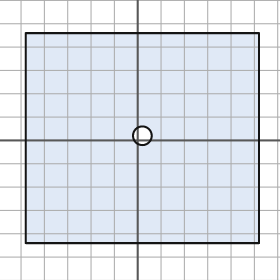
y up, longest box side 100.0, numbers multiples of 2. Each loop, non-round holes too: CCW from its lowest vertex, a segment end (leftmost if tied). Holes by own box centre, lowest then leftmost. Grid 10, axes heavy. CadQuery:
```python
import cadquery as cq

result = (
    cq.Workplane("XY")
    .moveTo(-48.0, -44.0)
    .lineTo(52.0, -44.0)
    .lineTo(52.0, 46.0)
    .lineTo(-48.0, 46.0)
    .close()
    .moveTo(2.0, 2.0)
    .circle(4.0)
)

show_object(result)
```